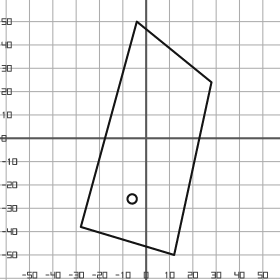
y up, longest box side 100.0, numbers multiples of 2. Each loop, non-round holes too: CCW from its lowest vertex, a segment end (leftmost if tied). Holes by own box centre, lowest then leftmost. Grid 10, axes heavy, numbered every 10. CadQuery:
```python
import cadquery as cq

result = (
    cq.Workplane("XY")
    .moveTo(12.0, -50.0)
    .lineTo(28.0, 24.0)
    .lineTo(-4.0, 50.0)
    .lineTo(-28.0, -38.0)
    .close()
    .moveTo(-6.0, -26.0)
    .circle(2.0)
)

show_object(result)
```